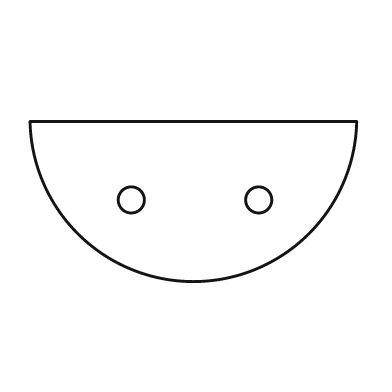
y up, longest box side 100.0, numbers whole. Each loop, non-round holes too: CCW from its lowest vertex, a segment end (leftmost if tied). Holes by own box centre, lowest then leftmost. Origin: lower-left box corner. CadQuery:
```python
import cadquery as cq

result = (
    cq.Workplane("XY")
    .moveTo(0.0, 49.0)
    .threePointArc((50.0, 0.0), (100.0, 49.0))
    .close()
    .moveTo(31.0, 25.0)
    .circle(4.0)
    .moveTo(70.0, 25.0)
    .circle(4.0)
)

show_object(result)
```